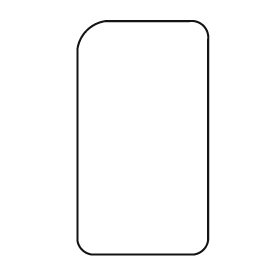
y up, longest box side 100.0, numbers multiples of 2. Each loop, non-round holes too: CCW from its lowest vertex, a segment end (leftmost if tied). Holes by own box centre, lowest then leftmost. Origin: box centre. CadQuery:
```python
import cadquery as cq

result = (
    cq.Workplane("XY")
    .moveTo(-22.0, -50.0)
    .lineTo(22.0, -50.0)
    .threePointArc((26.0, -48.0), (28.0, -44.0))
    .lineTo(28.0, 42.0)
    .threePointArc((26.0, 48.0), (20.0, 50.0))
    .lineTo(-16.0, 50.0)
    .threePointArc((-24.0, 46.0), (-28.0, 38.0))
    .lineTo(-28.0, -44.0)
    .threePointArc((-26.0, -48.0), (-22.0, -50.0))
    .close()
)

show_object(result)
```